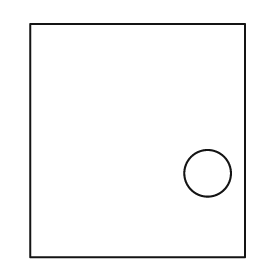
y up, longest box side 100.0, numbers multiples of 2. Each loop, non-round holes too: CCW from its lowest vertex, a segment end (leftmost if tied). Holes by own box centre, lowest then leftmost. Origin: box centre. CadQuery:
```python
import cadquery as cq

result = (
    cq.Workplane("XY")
    .moveTo(-46.0, -50.0)
    .lineTo(46.0, -50.0)
    .lineTo(46.0, 50.0)
    .lineTo(-46.0, 50.0)
    .close()
    .moveTo(30.0, -14.0)
    .circle(10.0)
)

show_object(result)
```